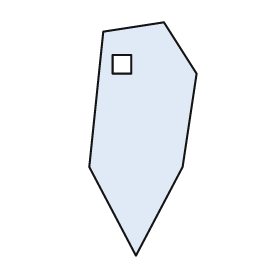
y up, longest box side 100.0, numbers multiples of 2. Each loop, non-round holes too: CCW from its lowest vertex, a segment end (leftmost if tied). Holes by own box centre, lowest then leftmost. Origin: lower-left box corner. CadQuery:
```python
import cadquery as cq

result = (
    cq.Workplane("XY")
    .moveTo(20.0, 0.0)
    .lineTo(40.0, 38.0)
    .lineTo(46.0, 78.0)
    .lineTo(32.0, 100.0)
    .lineTo(6.0, 96.0)
    .lineTo(0.0, 38.0)
    .close()
    .moveTo(10.0, 78.0)
    .lineTo(18.0, 78.0)
    .lineTo(18.0, 86.0)
    .lineTo(10.0, 86.0)
    .close()
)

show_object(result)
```